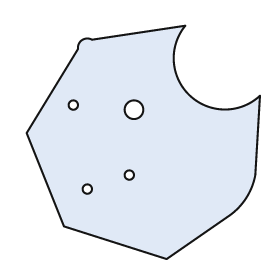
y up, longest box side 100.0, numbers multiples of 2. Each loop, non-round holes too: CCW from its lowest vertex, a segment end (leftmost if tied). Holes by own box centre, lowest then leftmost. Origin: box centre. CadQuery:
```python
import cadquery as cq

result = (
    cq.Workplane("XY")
    .moveTo(10.0, -50.0)
    .lineTo(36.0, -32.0)
    .threePointArc((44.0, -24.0), (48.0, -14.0))
    .lineTo(50.0, 20.0)
    .threePointArc((20.0, 20.0), (18.0, 50.0))
    .lineTo(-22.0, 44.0)
    .threePointArc((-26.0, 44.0), (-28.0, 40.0))
    .lineTo(-50.0, 4.0)
    .lineTo(-34.0, -36.0)
    .close()
    .moveTo(-24.0, -20.0)
    .circle(2.0)
    .moveTo(-6.0, -14.0)
    .circle(2.0)
    .moveTo(-4.0, 14.0)
    .circle(4.0)
    .moveTo(-30.0, 16.0)
    .circle(2.0)
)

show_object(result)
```